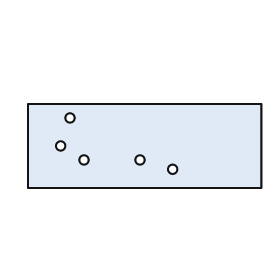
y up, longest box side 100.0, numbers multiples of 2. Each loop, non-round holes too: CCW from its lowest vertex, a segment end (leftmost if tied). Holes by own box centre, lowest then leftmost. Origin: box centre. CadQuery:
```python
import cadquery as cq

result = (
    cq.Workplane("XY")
    .moveTo(-50.0, -18.0)
    .lineTo(50.0, -18.0)
    .lineTo(50.0, 18.0)
    .lineTo(-50.0, 18.0)
    .close()
    .moveTo(12.0, -10.0)
    .circle(2.0)
    .moveTo(-26.0, -6.0)
    .circle(2.0)
    .moveTo(-2.0, -6.0)
    .circle(2.0)
    .moveTo(-36.0, 0.0)
    .circle(2.0)
    .moveTo(-32.0, 12.0)
    .circle(2.0)
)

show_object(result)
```